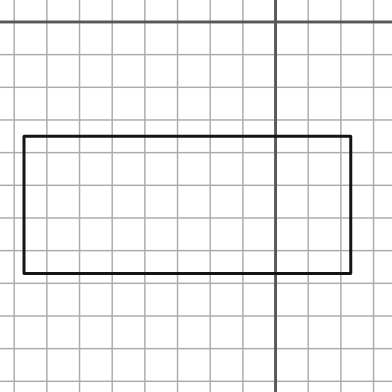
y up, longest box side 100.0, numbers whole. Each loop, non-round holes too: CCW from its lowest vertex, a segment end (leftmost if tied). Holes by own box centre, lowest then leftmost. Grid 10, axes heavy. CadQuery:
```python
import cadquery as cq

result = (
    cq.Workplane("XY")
    .moveTo(-77.0, -77.0)
    .lineTo(23.0, -77.0)
    .lineTo(23.0, -35.0)
    .lineTo(-77.0, -35.0)
    .close()
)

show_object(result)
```